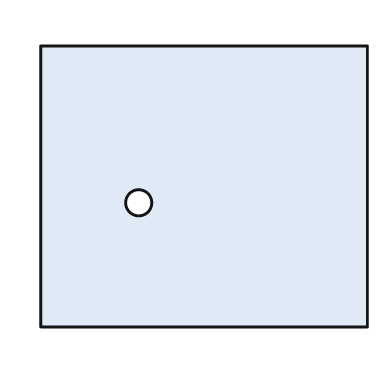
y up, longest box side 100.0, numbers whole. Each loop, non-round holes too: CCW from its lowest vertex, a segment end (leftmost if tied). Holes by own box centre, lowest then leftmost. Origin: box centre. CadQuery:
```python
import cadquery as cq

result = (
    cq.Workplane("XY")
    .moveTo(-50.0, -43.0)
    .lineTo(50.0, -43.0)
    .lineTo(50.0, 43.0)
    .lineTo(-50.0, 43.0)
    .close()
    .moveTo(-20.0, -5.0)
    .circle(4.0)
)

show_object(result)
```